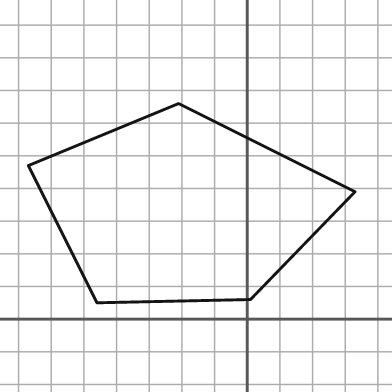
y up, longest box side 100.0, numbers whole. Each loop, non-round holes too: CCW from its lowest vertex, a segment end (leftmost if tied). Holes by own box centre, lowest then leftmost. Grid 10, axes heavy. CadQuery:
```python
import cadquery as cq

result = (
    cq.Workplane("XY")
    .moveTo(-46.0, 5.0)
    .lineTo(1.0, 6.0)
    .lineTo(33.0, 39.0)
    .lineTo(-21.0, 66.0)
    .lineTo(-67.0, 47.0)
    .close()
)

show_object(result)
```